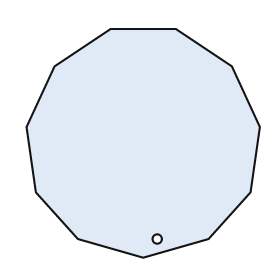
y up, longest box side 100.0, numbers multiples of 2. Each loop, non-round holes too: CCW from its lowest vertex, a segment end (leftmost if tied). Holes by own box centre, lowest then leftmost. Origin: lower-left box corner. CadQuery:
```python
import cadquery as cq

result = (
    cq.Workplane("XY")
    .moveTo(50.0, 0.0)
    .lineTo(78.0, 8.0)
    .lineTo(96.0, 28.0)
    .lineTo(100.0, 56.0)
    .lineTo(88.0, 82.0)
    .lineTo(64.0, 98.0)
    .lineTo(36.0, 98.0)
    .lineTo(12.0, 82.0)
    .lineTo(0.0, 56.0)
    .lineTo(4.0, 28.0)
    .lineTo(22.0, 8.0)
    .close()
    .moveTo(56.0, 8.0)
    .circle(2.0)
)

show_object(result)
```